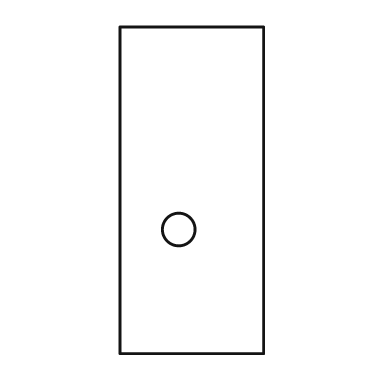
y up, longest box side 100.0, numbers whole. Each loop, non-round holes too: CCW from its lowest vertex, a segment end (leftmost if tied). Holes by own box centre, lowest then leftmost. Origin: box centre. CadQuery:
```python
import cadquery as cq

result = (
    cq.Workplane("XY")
    .moveTo(-22.0, -50.0)
    .lineTo(22.0, -50.0)
    .lineTo(22.0, 50.0)
    .lineTo(-22.0, 50.0)
    .close()
    .moveTo(-4.0, -12.0)
    .circle(5.0)
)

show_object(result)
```